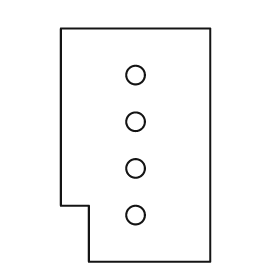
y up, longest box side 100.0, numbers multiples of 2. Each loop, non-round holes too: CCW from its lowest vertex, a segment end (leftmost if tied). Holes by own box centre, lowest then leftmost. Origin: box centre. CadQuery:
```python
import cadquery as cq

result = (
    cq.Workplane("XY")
    .moveTo(-20.0, -50.0)
    .lineTo(32.0, -50.0)
    .lineTo(32.0, 50.0)
    .lineTo(-32.0, 50.0)
    .lineTo(-32.0, -26.0)
    .lineTo(-20.0, -26.0)
    .close()
    .moveTo(0.0, -30.0)
    .circle(4.0)
    .moveTo(0.0, -10.0)
    .circle(4.0)
    .moveTo(0.0, 10.0)
    .circle(4.0)
    .moveTo(0.0, 30.0)
    .circle(4.0)
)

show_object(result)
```